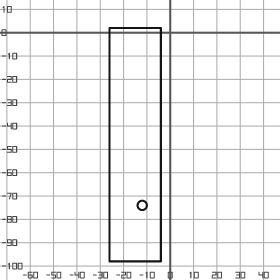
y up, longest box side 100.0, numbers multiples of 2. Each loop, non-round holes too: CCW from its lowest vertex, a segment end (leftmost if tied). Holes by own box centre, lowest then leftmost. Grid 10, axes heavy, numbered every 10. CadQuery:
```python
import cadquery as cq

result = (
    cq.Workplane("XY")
    .moveTo(-26.0, -98.0)
    .lineTo(-4.0, -98.0)
    .lineTo(-4.0, 2.0)
    .lineTo(-26.0, 2.0)
    .close()
    .moveTo(-12.0, -74.0)
    .circle(2.0)
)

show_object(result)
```